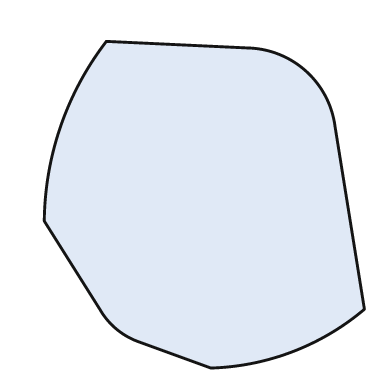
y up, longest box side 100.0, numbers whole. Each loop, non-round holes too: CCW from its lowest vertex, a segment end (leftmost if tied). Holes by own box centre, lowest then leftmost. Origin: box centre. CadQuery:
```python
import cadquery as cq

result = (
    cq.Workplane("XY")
    .moveTo(2.0, -50.0)
    .threePointArc((27.0, -45.0), (49.0, -32.0))
    .lineTo(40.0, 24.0)
    .threePointArc((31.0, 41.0), (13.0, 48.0))
    .lineTo(-30.0, 50.0)
    .threePointArc((-44.0, 24.0), (-49.0, -5.0))
    .lineTo(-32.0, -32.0)
    .threePointArc((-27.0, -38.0), (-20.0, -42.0))
    .close()
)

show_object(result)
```